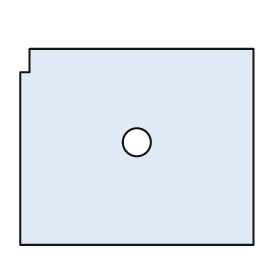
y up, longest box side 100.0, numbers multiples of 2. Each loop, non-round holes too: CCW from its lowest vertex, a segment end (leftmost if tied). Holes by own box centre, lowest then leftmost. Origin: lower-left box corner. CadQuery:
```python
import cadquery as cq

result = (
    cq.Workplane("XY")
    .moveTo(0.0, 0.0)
    .lineTo(100.0, 0.0)
    .lineTo(100.0, 84.0)
    .lineTo(4.0, 84.0)
    .lineTo(4.0, 74.0)
    .lineTo(0.0, 74.0)
    .close()
    .moveTo(50.0, 44.0)
    .circle(6.0)
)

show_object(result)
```